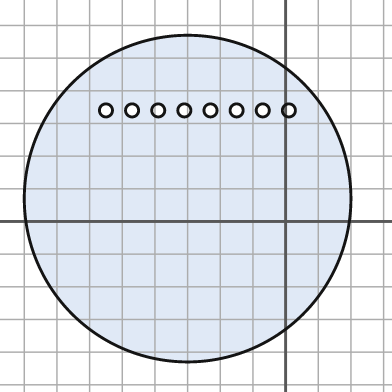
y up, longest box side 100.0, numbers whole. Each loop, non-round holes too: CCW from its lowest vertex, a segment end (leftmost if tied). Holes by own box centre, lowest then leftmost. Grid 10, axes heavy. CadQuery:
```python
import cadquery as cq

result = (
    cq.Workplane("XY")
    .moveTo(-30.0, 7.0)
    .circle(50.0)
    .moveTo(-55.0, 34.0)
    .circle(2.0)
    .moveTo(-47.0, 34.0)
    .circle(2.0)
    .moveTo(-39.0, 34.0)
    .circle(2.0)
    .moveTo(-31.0, 34.0)
    .circle(2.0)
    .moveTo(-23.0, 34.0)
    .circle(2.0)
    .moveTo(-15.0, 34.0)
    .circle(2.0)
    .moveTo(-7.0, 34.0)
    .circle(2.0)
    .moveTo(1.0, 34.0)
    .circle(2.0)
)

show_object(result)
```